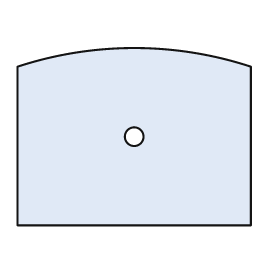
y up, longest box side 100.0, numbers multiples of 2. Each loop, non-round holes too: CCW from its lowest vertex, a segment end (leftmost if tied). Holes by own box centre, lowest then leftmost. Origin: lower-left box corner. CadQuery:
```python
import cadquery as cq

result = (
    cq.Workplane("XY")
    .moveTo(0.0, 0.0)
    .lineTo(100.0, 0.0)
    .lineTo(100.0, 68.0)
    .threePointArc((50.0, 76.0), (0.0, 68.0))
    .close()
    .moveTo(50.0, 38.0)
    .circle(4.0)
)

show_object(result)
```